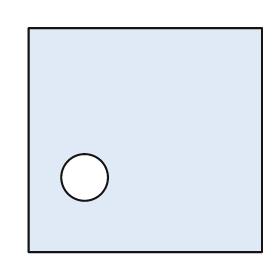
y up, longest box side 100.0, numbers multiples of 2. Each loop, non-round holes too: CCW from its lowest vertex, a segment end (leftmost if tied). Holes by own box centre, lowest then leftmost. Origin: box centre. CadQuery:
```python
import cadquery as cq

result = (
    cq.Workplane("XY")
    .moveTo(-50.0, -48.0)
    .lineTo(50.0, -48.0)
    .lineTo(50.0, 48.0)
    .lineTo(-50.0, 48.0)
    .close()
    .moveTo(-26.0, -16.0)
    .circle(10.0)
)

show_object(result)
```